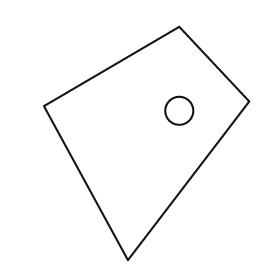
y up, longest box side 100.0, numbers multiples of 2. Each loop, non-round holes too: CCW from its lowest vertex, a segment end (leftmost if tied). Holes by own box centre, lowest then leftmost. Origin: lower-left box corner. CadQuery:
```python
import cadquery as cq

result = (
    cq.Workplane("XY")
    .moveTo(36.0, 0.0)
    .lineTo(88.0, 68.0)
    .lineTo(58.0, 100.0)
    .lineTo(0.0, 66.0)
    .close()
    .moveTo(58.0, 64.0)
    .circle(6.0)
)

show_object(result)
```